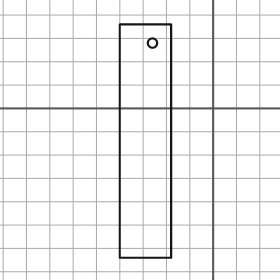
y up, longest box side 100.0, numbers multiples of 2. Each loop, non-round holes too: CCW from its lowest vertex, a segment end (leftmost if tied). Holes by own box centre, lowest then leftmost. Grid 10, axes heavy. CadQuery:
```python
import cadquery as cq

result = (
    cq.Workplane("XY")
    .moveTo(-40.0, -64.0)
    .lineTo(-18.0, -64.0)
    .lineTo(-18.0, 36.0)
    .lineTo(-40.0, 36.0)
    .close()
    .moveTo(-26.0, 28.0)
    .circle(2.0)
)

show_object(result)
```